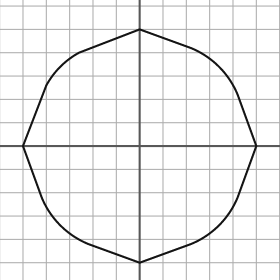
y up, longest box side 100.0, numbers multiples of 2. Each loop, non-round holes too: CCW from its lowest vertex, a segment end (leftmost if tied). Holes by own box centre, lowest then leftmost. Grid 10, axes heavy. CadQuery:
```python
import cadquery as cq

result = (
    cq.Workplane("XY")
    .moveTo(0.0, -50.0)
    .lineTo(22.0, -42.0)
    .threePointArc((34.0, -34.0), (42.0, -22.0))
    .lineTo(50.0, 0.0)
    .lineTo(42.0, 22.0)
    .threePointArc((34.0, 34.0), (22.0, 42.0))
    .lineTo(0.0, 50.0)
    .lineTo(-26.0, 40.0)
    .threePointArc((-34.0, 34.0), (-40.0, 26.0))
    .lineTo(-50.0, 0.0)
    .lineTo(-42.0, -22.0)
    .threePointArc((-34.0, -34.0), (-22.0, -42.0))
    .close()
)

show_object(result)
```